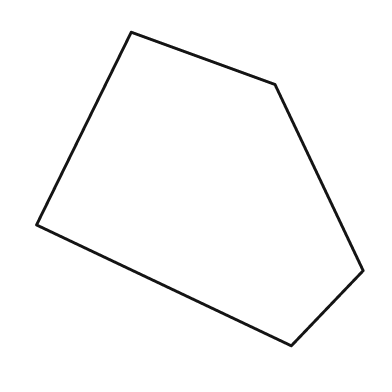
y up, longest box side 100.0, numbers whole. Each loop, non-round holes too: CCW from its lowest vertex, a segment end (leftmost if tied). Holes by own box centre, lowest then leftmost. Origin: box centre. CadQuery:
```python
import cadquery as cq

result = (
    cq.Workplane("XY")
    .moveTo(28.0, -48.0)
    .lineTo(50.0, -25.0)
    .lineTo(23.0, 32.0)
    .lineTo(-21.0, 48.0)
    .lineTo(-50.0, -11.0)
    .close()
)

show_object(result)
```